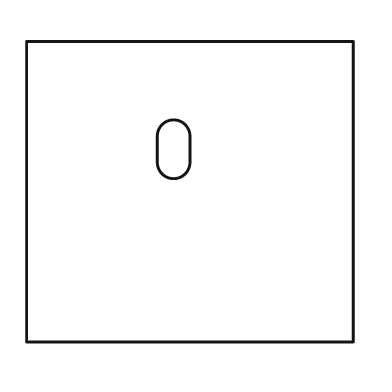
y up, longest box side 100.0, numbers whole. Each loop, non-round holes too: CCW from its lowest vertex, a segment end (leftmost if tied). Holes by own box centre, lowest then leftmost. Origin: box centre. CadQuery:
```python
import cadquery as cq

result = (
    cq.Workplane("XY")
    .moveTo(-50.0, -46.0)
    .lineTo(50.0, -46.0)
    .lineTo(50.0, 46.0)
    .lineTo(-50.0, 46.0)
    .close()
    .moveTo(-10.0, 9.0)
    .threePointArc((-5.0, 4.0), (0.0, 9.0))
    .lineTo(0.0, 17.0)
    .threePointArc((-5.0, 22.0), (-10.0, 17.0))
    .close()
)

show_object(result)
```